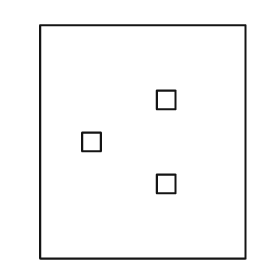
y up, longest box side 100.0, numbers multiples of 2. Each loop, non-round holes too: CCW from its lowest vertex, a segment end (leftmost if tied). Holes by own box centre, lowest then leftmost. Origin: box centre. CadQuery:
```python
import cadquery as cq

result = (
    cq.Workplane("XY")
    .moveTo(-44.0, -50.0)
    .lineTo(44.0, -50.0)
    .lineTo(44.0, 50.0)
    .lineTo(-44.0, 50.0)
    .close()
    .moveTo(6.0, -22.0)
    .lineTo(14.0, -22.0)
    .lineTo(14.0, -14.0)
    .lineTo(6.0, -14.0)
    .close()
    .moveTo(-26.0, -4.0)
    .lineTo(-18.0, -4.0)
    .lineTo(-18.0, 4.0)
    .lineTo(-26.0, 4.0)
    .close()
    .moveTo(6.0, 14.0)
    .lineTo(14.0, 14.0)
    .lineTo(14.0, 22.0)
    .lineTo(6.0, 22.0)
    .close()
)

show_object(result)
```